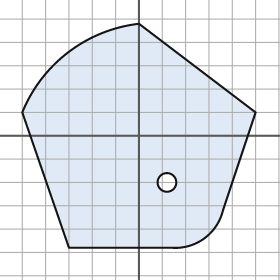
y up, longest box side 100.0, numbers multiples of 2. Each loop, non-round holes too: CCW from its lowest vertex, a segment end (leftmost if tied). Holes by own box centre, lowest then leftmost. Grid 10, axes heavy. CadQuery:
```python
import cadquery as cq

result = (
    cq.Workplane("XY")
    .moveTo(-30.0, -48.0)
    .lineTo(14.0, -48.0)
    .threePointArc((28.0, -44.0), (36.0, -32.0))
    .lineTo(50.0, 10.0)
    .lineTo(0.0, 48.0)
    .threePointArc((-30.0, 36.0), (-50.0, 10.0))
    .close()
    .moveTo(12.0, -20.0)
    .circle(4.0)
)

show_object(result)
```